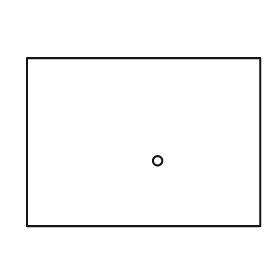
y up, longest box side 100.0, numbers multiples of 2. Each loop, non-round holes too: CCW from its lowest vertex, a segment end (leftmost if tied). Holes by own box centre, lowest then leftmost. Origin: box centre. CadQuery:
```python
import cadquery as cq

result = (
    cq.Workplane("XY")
    .moveTo(-50.0, -36.0)
    .lineTo(50.0, -36.0)
    .lineTo(50.0, 36.0)
    .lineTo(-50.0, 36.0)
    .close()
    .moveTo(6.0, -8.0)
    .circle(2.0)
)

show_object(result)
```